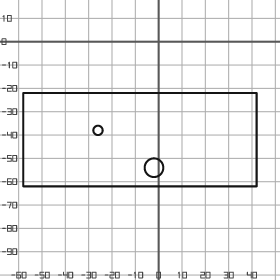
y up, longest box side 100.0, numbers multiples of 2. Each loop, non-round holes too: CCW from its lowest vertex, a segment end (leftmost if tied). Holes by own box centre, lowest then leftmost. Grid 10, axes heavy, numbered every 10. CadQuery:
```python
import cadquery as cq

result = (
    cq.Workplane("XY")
    .moveTo(-58.0, -62.0)
    .lineTo(42.0, -62.0)
    .lineTo(42.0, -22.0)
    .lineTo(-58.0, -22.0)
    .close()
    .moveTo(-2.0, -54.0)
    .circle(4.0)
    .moveTo(-26.0, -38.0)
    .circle(2.0)
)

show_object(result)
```